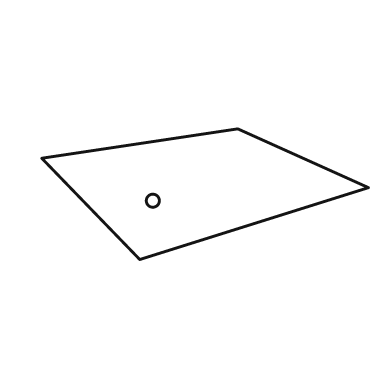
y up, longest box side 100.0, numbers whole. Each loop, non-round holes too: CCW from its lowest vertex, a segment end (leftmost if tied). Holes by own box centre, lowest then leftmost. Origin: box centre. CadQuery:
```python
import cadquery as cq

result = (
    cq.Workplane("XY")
    .moveTo(-20.0, -20.0)
    .lineTo(50.0, 2.0)
    .lineTo(10.0, 20.0)
    .lineTo(-50.0, 11.0)
    .close()
    .moveTo(-16.0, -2.0)
    .circle(2.0)
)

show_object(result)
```